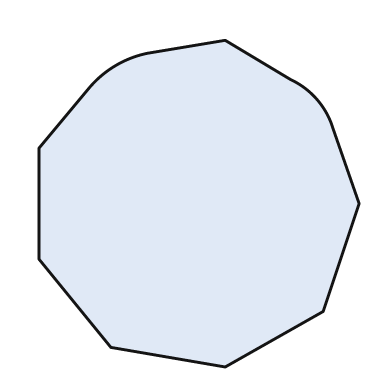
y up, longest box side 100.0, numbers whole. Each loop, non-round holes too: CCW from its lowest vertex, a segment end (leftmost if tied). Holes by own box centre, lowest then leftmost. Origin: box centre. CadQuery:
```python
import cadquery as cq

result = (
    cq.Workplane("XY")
    .moveTo(8.0, -50.0)
    .lineTo(38.0, -33.0)
    .lineTo(49.0, 0.0)
    .lineTo(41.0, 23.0)
    .threePointArc((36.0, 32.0), (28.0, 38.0))
    .lineTo(8.0, 50.0)
    .lineTo(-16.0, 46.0)
    .threePointArc((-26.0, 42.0), (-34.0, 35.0))
    .lineTo(-49.0, 17.0)
    .lineTo(-49.0, -17.0)
    .lineTo(-27.0, -44.0)
    .close()
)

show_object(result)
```